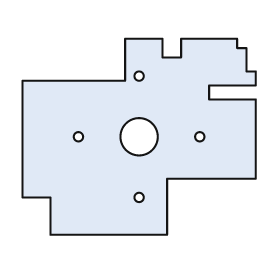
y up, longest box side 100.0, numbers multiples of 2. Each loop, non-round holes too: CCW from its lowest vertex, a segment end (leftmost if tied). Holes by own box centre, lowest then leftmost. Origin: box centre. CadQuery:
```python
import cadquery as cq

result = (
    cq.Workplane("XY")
    .moveTo(-38.0, -42.0)
    .lineTo(12.0, -42.0)
    .lineTo(12.0, -18.0)
    .lineTo(50.0, -18.0)
    .lineTo(50.0, 16.0)
    .lineTo(30.0, 16.0)
    .lineTo(30.0, 22.0)
    .lineTo(50.0, 22.0)
    .lineTo(50.0, 28.0)
    .lineTo(46.0, 28.0)
    .lineTo(46.0, 38.0)
    .lineTo(42.0, 38.0)
    .lineTo(42.0, 42.0)
    .lineTo(18.0, 42.0)
    .lineTo(18.0, 34.0)
    .lineTo(10.0, 34.0)
    .lineTo(10.0, 42.0)
    .lineTo(-6.0, 42.0)
    .lineTo(-6.0, 24.0)
    .lineTo(-50.0, 24.0)
    .lineTo(-50.0, -26.0)
    .lineTo(-38.0, -26.0)
    .close()
    .moveTo(0.0, -26.0)
    .circle(2.0)
    .moveTo(-26.0, 0.0)
    .circle(2.0)
    .moveTo(0.0, 0.0)
    .circle(8.0)
    .moveTo(26.0, 0.0)
    .circle(2.0)
    .moveTo(0.0, 26.0)
    .circle(2.0)
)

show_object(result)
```